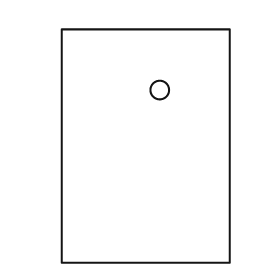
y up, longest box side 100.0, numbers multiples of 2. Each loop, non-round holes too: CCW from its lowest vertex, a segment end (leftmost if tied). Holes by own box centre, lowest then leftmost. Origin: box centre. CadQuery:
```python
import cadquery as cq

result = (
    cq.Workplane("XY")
    .moveTo(-36.0, -50.0)
    .lineTo(36.0, -50.0)
    .lineTo(36.0, 50.0)
    .lineTo(-36.0, 50.0)
    .close()
    .moveTo(6.0, 24.0)
    .circle(4.0)
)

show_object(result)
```